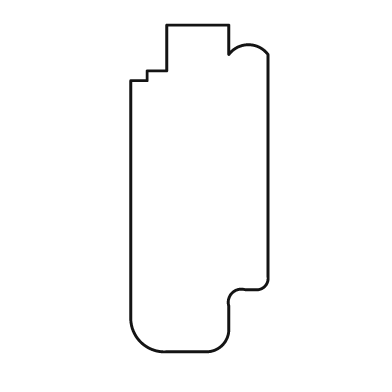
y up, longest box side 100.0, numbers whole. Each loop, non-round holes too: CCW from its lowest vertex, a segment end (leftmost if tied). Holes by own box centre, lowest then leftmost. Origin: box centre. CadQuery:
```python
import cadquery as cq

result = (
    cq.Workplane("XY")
    .moveTo(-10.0, -50.0)
    .lineTo(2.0, -50.0)
    .threePointArc((7.0, -48.0), (9.0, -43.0))
    .lineTo(9.0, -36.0)
    .threePointArc((10.0, -32.0), (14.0, -31.0))
    .lineTo(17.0, -31.0)
    .threePointArc((20.0, -30.0), (21.0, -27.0))
    .lineTo(21.0, 41.0)
    .threePointArc((15.0, 44.0), (9.0, 41.0))
    .lineTo(9.0, 50.0)
    .lineTo(-10.0, 50.0)
    .lineTo(-10.0, 36.0)
    .lineTo(-16.0, 36.0)
    .lineTo(-16.0, 33.0)
    .lineTo(-21.0, 33.0)
    .lineTo(-21.0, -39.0)
    .threePointArc((-18.0, -47.0), (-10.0, -50.0))
    .close()
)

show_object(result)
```